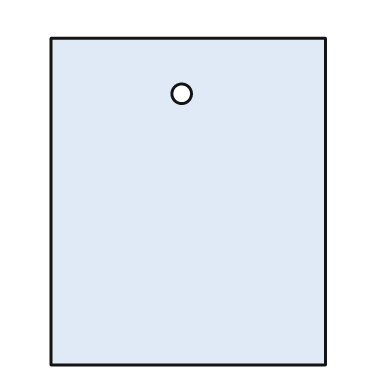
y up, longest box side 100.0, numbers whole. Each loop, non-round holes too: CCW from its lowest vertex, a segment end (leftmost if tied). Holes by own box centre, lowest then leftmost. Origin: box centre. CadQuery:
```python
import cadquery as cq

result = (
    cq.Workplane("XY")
    .moveTo(-42.0, -50.0)
    .lineTo(42.0, -50.0)
    .lineTo(42.0, 50.0)
    .lineTo(-42.0, 50.0)
    .close()
    .moveTo(-2.0, 33.0)
    .circle(3.0)
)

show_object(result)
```